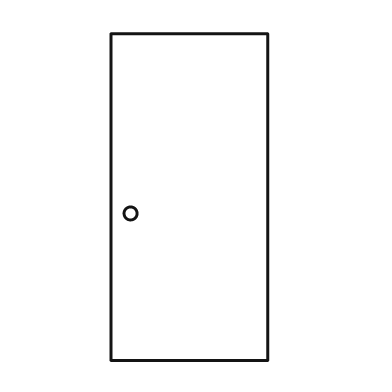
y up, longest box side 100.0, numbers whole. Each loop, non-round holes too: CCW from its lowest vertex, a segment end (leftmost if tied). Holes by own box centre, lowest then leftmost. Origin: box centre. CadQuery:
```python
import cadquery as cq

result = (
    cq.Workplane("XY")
    .moveTo(-24.0, -50.0)
    .lineTo(24.0, -50.0)
    .lineTo(24.0, 50.0)
    .lineTo(-24.0, 50.0)
    .close()
    .moveTo(-18.0, -5.0)
    .circle(2.0)
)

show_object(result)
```